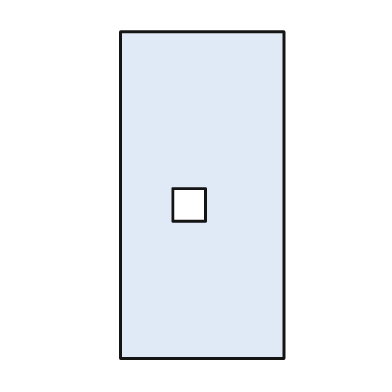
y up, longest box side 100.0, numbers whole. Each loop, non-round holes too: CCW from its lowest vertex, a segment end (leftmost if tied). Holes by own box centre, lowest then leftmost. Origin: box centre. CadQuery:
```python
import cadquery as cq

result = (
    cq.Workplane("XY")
    .moveTo(-25.0, -50.0)
    .lineTo(25.0, -50.0)
    .lineTo(25.0, 50.0)
    .lineTo(-25.0, 50.0)
    .close()
    .moveTo(-9.0, -8.0)
    .lineTo(1.0, -8.0)
    .lineTo(1.0, 2.0)
    .lineTo(-9.0, 2.0)
    .close()
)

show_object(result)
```